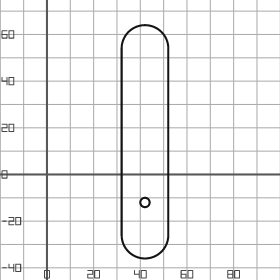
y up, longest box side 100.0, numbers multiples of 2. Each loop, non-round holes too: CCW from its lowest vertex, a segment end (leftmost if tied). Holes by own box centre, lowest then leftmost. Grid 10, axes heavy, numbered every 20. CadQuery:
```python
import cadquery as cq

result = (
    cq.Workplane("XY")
    .moveTo(32.0, -26.0)
    .threePointArc((42.0, -36.0), (52.0, -26.0))
    .lineTo(52.0, 54.0)
    .threePointArc((42.0, 64.0), (32.0, 54.0))
    .close()
    .moveTo(42.0, -12.0)
    .circle(2.0)
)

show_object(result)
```